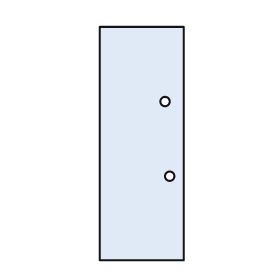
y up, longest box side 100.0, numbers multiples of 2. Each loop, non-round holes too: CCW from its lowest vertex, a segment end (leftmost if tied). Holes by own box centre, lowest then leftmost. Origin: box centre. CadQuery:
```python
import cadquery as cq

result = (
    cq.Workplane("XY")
    .moveTo(-18.0, -50.0)
    .lineTo(18.0, -50.0)
    .lineTo(18.0, 50.0)
    .lineTo(-18.0, 50.0)
    .close()
    .moveTo(12.0, -14.0)
    .circle(2.0)
    .moveTo(10.0, 18.0)
    .circle(2.0)
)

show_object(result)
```